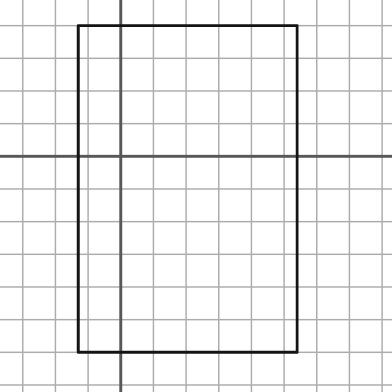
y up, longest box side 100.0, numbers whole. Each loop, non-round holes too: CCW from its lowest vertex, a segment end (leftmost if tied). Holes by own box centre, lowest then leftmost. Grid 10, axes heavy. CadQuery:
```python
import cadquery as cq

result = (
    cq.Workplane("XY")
    .moveTo(-13.0, -60.0)
    .lineTo(54.0, -60.0)
    .lineTo(54.0, 40.0)
    .lineTo(-13.0, 40.0)
    .close()
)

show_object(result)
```